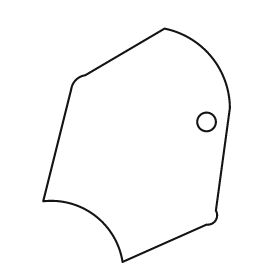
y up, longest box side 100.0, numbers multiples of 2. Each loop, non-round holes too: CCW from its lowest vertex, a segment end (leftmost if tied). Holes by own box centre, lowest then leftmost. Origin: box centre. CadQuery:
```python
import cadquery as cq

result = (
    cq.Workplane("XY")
    .moveTo(-6.0, -50.0)
    .lineTo(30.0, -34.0)
    .threePointArc((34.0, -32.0), (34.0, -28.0))
    .lineTo(40.0, 16.0)
    .threePointArc((32.0, 38.0), (12.0, 50.0))
    .lineTo(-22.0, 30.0)
    .threePointArc((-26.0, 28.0), (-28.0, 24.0))
    .lineTo(-40.0, -24.0)
    .threePointArc((-18.0, -30.0), (-6.0, -50.0))
    .close()
    .moveTo(30.0, 10.0)
    .circle(4.0)
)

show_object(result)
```